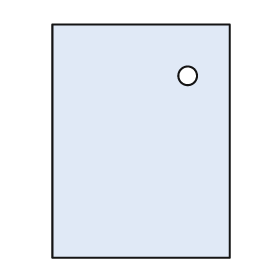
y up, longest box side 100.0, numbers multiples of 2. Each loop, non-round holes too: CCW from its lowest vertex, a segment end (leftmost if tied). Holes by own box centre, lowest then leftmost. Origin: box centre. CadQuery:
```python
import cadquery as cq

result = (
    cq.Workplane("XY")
    .moveTo(-38.0, -50.0)
    .lineTo(38.0, -50.0)
    .lineTo(38.0, 50.0)
    .lineTo(-38.0, 50.0)
    .close()
    .moveTo(20.0, 28.0)
    .circle(4.0)
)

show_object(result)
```